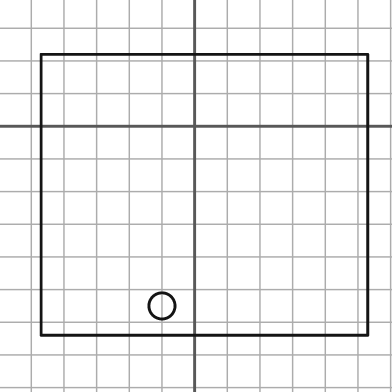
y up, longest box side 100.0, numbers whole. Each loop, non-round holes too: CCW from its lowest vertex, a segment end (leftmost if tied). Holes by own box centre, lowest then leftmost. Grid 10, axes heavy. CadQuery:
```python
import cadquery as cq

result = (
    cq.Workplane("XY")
    .moveTo(-47.0, -64.0)
    .lineTo(53.0, -64.0)
    .lineTo(53.0, 22.0)
    .lineTo(-47.0, 22.0)
    .close()
    .moveTo(-10.0, -55.0)
    .circle(4.0)
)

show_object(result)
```